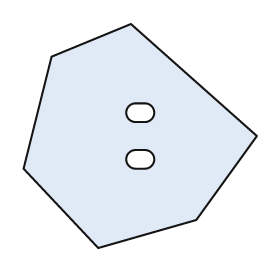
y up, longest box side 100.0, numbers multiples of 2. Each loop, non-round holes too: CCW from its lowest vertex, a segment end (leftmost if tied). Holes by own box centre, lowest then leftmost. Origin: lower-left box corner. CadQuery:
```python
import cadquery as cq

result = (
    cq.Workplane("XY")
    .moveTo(32.0, 0.0)
    .lineTo(74.0, 12.0)
    .lineTo(100.0, 48.0)
    .lineTo(46.0, 96.0)
    .lineTo(12.0, 82.0)
    .lineTo(0.0, 34.0)
    .close()
    .moveTo(48.0, 34.0)
    .lineTo(52.0, 34.0)
    .threePointArc((56.0, 38.0), (52.0, 42.0))
    .lineTo(48.0, 42.0)
    .threePointArc((44.0, 38.0), (48.0, 34.0))
    .close()
    .moveTo(48.0, 54.0)
    .lineTo(52.0, 54.0)
    .threePointArc((56.0, 58.0), (52.0, 62.0))
    .lineTo(48.0, 62.0)
    .threePointArc((44.0, 58.0), (48.0, 54.0))
    .close()
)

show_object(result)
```